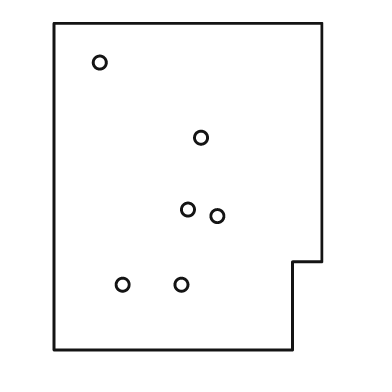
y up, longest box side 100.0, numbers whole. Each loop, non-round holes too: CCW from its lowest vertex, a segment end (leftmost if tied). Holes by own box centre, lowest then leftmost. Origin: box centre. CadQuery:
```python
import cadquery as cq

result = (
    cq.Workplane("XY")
    .moveTo(-41.0, -50.0)
    .lineTo(32.0, -50.0)
    .lineTo(32.0, -23.0)
    .lineTo(41.0, -23.0)
    .lineTo(41.0, 50.0)
    .lineTo(-41.0, 50.0)
    .close()
    .moveTo(-20.0, -30.0)
    .circle(2.0)
    .moveTo(-2.0, -30.0)
    .circle(2.0)
    .moveTo(9.0, -9.0)
    .circle(2.0)
    .moveTo(0.0, -7.0)
    .circle(2.0)
    .moveTo(4.0, 15.0)
    .circle(2.0)
    .moveTo(-27.0, 38.0)
    .circle(2.0)
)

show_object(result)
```